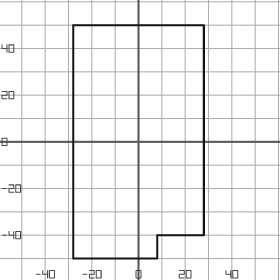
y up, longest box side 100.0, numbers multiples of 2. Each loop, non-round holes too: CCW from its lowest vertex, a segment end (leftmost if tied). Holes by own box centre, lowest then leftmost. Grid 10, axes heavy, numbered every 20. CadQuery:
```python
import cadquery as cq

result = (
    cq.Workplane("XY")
    .moveTo(-28.0, -50.0)
    .lineTo(8.0, -50.0)
    .lineTo(8.0, -40.0)
    .lineTo(28.0, -40.0)
    .lineTo(28.0, 50.0)
    .lineTo(-28.0, 50.0)
    .close()
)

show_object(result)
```